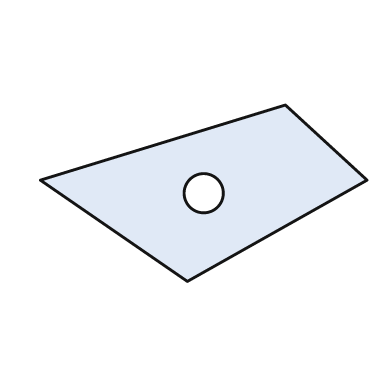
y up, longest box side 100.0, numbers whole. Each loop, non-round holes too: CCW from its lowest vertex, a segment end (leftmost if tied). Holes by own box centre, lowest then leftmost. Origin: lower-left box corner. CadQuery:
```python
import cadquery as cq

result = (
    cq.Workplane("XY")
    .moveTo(45.0, 0.0)
    .lineTo(100.0, 31.0)
    .lineTo(75.0, 54.0)
    .lineTo(0.0, 31.0)
    .close()
    .moveTo(50.0, 27.0)
    .circle(6.0)
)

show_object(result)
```